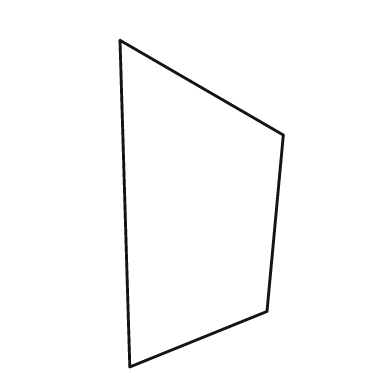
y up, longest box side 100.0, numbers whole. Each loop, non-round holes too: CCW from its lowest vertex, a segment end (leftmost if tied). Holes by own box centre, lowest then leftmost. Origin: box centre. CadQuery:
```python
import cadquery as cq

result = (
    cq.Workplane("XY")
    .moveTo(-22.0, -50.0)
    .lineTo(20.0, -33.0)
    .lineTo(25.0, 21.0)
    .lineTo(-25.0, 50.0)
    .close()
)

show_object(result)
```